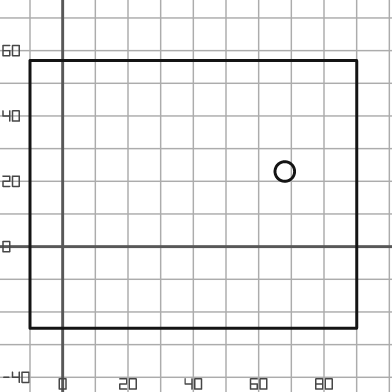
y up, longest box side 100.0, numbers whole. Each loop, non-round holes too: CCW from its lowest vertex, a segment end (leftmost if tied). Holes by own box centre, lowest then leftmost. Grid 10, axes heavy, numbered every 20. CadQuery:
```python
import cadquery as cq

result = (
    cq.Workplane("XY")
    .moveTo(-10.0, -25.0)
    .lineTo(90.0, -25.0)
    .lineTo(90.0, 57.0)
    .lineTo(-10.0, 57.0)
    .close()
    .moveTo(68.0, 23.0)
    .circle(3.0)
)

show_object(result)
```